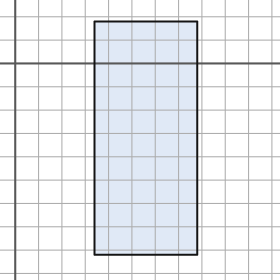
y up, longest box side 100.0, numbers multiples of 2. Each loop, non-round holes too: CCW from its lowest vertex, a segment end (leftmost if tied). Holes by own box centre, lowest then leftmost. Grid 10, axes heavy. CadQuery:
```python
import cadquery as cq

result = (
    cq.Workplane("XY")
    .moveTo(34.0, -82.0)
    .lineTo(78.0, -82.0)
    .lineTo(78.0, 18.0)
    .lineTo(34.0, 18.0)
    .close()
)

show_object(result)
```